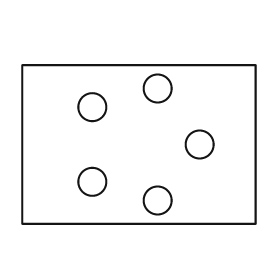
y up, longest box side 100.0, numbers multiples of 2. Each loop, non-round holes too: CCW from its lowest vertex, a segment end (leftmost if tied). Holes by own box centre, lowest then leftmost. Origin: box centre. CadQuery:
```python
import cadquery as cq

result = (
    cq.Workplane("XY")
    .moveTo(-50.0, -34.0)
    .lineTo(50.0, -34.0)
    .lineTo(50.0, 34.0)
    .lineTo(-50.0, 34.0)
    .close()
    .moveTo(8.0, -24.0)
    .circle(6.0)
    .moveTo(-20.0, -16.0)
    .circle(6.0)
    .moveTo(26.0, 0.0)
    .circle(6.0)
    .moveTo(-20.0, 16.0)
    .circle(6.0)
    .moveTo(8.0, 24.0)
    .circle(6.0)
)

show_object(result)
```